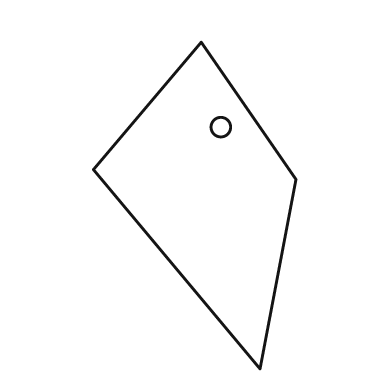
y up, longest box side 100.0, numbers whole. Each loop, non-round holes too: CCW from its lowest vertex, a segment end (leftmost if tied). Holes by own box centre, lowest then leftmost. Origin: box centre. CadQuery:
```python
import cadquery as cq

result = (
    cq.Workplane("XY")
    .moveTo(20.0, -50.0)
    .lineTo(31.0, 8.0)
    .lineTo(2.0, 50.0)
    .lineTo(-31.0, 11.0)
    .close()
    .moveTo(8.0, 24.0)
    .circle(3.0)
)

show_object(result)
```